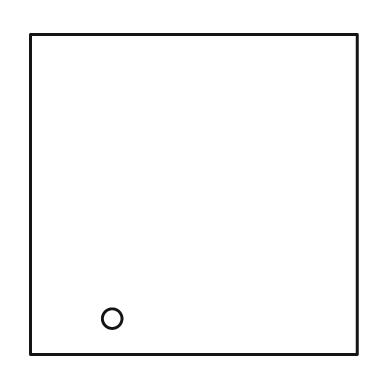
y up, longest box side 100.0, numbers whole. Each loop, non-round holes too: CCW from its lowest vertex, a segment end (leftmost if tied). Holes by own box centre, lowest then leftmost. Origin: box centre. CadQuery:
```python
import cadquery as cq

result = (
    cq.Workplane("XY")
    .moveTo(-50.0, -49.0)
    .lineTo(50.0, -49.0)
    .lineTo(50.0, 49.0)
    .lineTo(-50.0, 49.0)
    .close()
    .moveTo(-25.0, -38.0)
    .circle(3.0)
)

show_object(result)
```